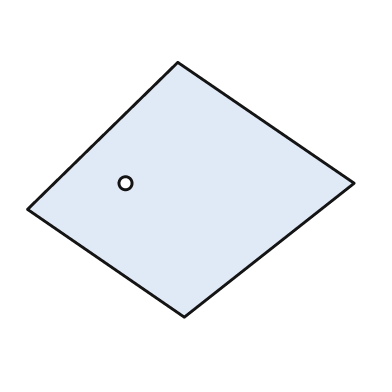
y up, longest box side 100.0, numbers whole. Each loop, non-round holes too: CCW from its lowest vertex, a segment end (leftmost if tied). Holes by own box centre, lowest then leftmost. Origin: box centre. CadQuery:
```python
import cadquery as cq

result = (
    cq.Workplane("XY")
    .moveTo(-2.0, -39.0)
    .lineTo(50.0, 2.0)
    .lineTo(-4.0, 39.0)
    .lineTo(-50.0, -6.0)
    .close()
    .moveTo(-20.0, 2.0)
    .circle(2.0)
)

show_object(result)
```